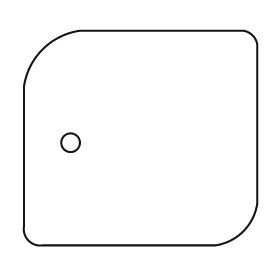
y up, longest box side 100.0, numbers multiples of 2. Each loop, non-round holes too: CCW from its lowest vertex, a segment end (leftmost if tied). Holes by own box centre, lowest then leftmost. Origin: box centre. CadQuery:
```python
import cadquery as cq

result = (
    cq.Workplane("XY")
    .moveTo(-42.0, -46.0)
    .lineTo(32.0, -46.0)
    .threePointArc((44.0, -40.0), (50.0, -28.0))
    .lineTo(50.0, 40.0)
    .threePointArc((48.0, 44.0), (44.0, 46.0))
    .lineTo(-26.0, 46.0)
    .threePointArc((-42.0, 38.0), (-50.0, 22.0))
    .lineTo(-50.0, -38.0)
    .threePointArc((-48.0, -44.0), (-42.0, -46.0))
    .close()
    .moveTo(-30.0, -2.0)
    .circle(4.0)
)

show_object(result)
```